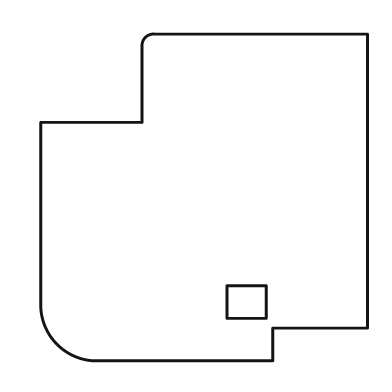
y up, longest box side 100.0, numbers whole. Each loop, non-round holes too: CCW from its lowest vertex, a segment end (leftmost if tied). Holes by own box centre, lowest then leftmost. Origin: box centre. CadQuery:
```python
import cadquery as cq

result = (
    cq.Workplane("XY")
    .moveTo(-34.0, -50.0)
    .lineTo(21.0, -50.0)
    .lineTo(21.0, -40.0)
    .lineTo(50.0, -40.0)
    .lineTo(50.0, 50.0)
    .lineTo(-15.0, 50.0)
    .threePointArc((-18.0, 49.0), (-19.0, 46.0))
    .lineTo(-19.0, 23.0)
    .lineTo(-50.0, 23.0)
    .lineTo(-50.0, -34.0)
    .threePointArc((-45.0, -45.0), (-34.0, -50.0))
    .close()
    .moveTo(7.0, -37.0)
    .lineTo(19.0, -37.0)
    .lineTo(19.0, -27.0)
    .lineTo(7.0, -27.0)
    .close()
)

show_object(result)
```